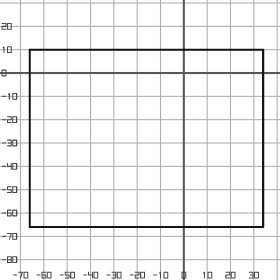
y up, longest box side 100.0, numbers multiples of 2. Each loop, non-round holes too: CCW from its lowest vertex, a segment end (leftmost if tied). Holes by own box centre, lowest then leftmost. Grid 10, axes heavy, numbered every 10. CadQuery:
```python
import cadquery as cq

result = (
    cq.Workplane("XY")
    .moveTo(-66.0, -66.0)
    .lineTo(34.0, -66.0)
    .lineTo(34.0, 10.0)
    .lineTo(-66.0, 10.0)
    .close()
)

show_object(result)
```